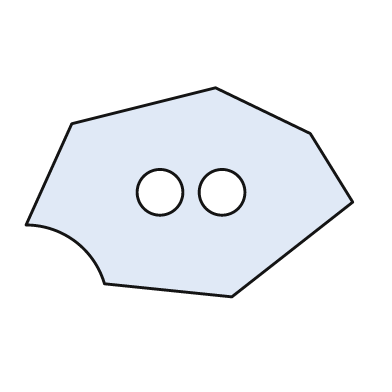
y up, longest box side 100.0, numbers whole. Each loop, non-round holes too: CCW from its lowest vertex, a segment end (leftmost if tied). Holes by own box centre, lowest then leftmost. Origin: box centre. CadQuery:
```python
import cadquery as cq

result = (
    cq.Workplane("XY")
    .moveTo(13.0, -32.0)
    .lineTo(50.0, -3.0)
    .lineTo(37.0, 18.0)
    .lineTo(8.0, 32.0)
    .lineTo(-36.0, 21.0)
    .lineTo(-50.0, -10.0)
    .threePointArc((-35.0, -15.0), (-26.0, -28.0))
    .close()
    .moveTo(-9.0, 0.0)
    .circle(7.0)
    .moveTo(10.0, 0.0)
    .circle(7.0)
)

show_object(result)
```